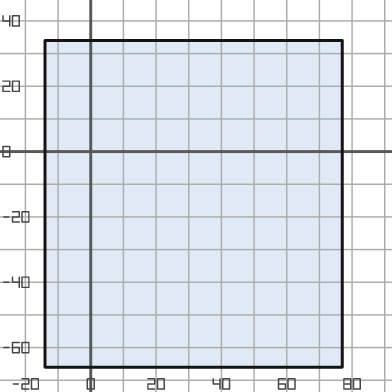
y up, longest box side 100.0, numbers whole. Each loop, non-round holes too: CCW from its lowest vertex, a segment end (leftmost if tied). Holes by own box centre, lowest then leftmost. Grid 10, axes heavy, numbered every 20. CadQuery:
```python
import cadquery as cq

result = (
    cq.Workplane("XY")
    .moveTo(-14.0, -66.0)
    .lineTo(77.0, -66.0)
    .lineTo(77.0, 34.0)
    .lineTo(-14.0, 34.0)
    .close()
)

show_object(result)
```